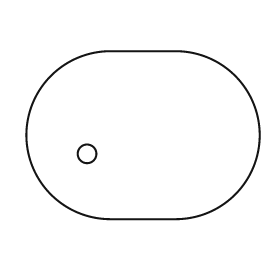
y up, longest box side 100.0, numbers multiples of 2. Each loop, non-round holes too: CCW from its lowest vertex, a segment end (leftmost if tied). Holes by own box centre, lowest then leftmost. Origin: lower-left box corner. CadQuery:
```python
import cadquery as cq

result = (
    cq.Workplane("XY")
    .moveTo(36.0, 0.0)
    .lineTo(64.0, 0.0)
    .threePointArc((100.0, 36.0), (64.0, 72.0))
    .lineTo(36.0, 72.0)
    .threePointArc((0.0, 36.0), (36.0, 0.0))
    .close()
    .moveTo(26.0, 28.0)
    .circle(4.0)
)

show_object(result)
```